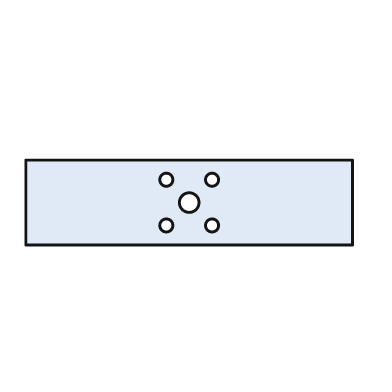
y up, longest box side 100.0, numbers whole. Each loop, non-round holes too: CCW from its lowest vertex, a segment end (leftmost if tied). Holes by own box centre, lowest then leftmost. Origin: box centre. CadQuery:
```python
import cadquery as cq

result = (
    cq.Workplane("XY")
    .moveTo(-50.0, -13.0)
    .lineTo(50.0, -13.0)
    .lineTo(50.0, 13.0)
    .lineTo(-50.0, 13.0)
    .close()
    .moveTo(-7.0, -7.0)
    .circle(2.0)
    .moveTo(7.0, -7.0)
    .circle(2.0)
    .moveTo(0.0, 0.0)
    .circle(3.0)
    .moveTo(-7.0, 7.0)
    .circle(2.0)
    .moveTo(7.0, 7.0)
    .circle(2.0)
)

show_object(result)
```